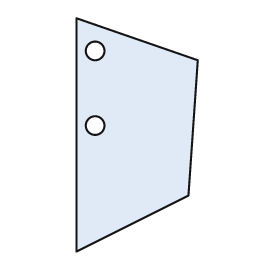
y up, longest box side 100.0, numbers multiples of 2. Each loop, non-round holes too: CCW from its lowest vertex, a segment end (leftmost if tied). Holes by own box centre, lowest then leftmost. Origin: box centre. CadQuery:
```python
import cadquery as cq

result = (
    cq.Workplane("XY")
    .moveTo(-26.0, -50.0)
    .lineTo(22.0, -26.0)
    .lineTo(26.0, 32.0)
    .lineTo(-26.0, 50.0)
    .close()
    .moveTo(-18.0, 4.0)
    .circle(4.0)
    .moveTo(-18.0, 36.0)
    .circle(4.0)
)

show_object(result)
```